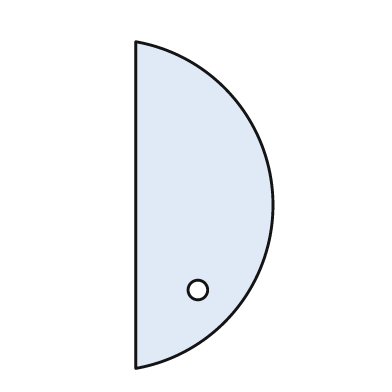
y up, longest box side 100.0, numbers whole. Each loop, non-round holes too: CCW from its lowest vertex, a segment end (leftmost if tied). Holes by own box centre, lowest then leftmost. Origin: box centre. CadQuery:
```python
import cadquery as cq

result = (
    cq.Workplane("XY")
    .moveTo(-21.0, -50.0)
    .threePointArc((21.0, 0.0), (-21.0, 50.0))
    .close()
    .moveTo(-2.0, -26.0)
    .circle(3.0)
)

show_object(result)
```